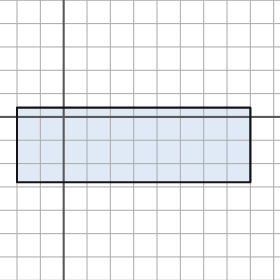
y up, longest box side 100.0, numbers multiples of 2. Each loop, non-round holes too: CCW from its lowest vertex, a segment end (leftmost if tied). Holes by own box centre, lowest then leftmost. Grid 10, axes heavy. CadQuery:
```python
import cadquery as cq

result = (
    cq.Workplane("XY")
    .moveTo(-20.0, -28.0)
    .lineTo(80.0, -28.0)
    .lineTo(80.0, 4.0)
    .lineTo(-20.0, 4.0)
    .close()
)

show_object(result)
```